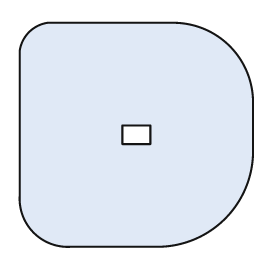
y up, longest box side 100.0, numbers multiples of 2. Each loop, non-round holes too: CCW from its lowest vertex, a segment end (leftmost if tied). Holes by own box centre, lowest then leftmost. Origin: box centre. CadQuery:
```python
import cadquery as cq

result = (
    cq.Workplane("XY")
    .moveTo(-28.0, -48.0)
    .lineTo(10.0, -48.0)
    .threePointArc((38.0, -36.0), (50.0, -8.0))
    .lineTo(50.0, 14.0)
    .threePointArc((40.0, 38.0), (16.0, 48.0))
    .lineTo(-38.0, 48.0)
    .threePointArc((-46.0, 44.0), (-50.0, 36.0))
    .lineTo(-50.0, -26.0)
    .threePointArc((-44.0, -42.0), (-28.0, -48.0))
    .close()
    .moveTo(-6.0, -4.0)
    .lineTo(6.0, -4.0)
    .lineTo(6.0, 4.0)
    .lineTo(-6.0, 4.0)
    .close()
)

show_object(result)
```